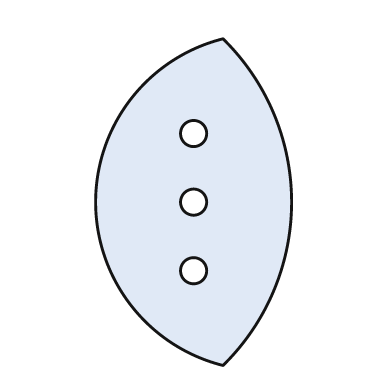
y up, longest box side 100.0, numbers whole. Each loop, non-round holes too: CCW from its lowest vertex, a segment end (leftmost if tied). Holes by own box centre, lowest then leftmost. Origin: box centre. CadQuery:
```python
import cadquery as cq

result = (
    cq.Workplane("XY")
    .moveTo(9.0, -50.0)
    .threePointArc((30.0, 0.0), (9.0, 50.0))
    .threePointArc((-30.0, 0.0), (9.0, -50.0))
    .close()
    .moveTo(0.0, -21.0)
    .circle(4.0)
    .moveTo(0.0, 0.0)
    .circle(4.0)
    .moveTo(0.0, 21.0)
    .circle(4.0)
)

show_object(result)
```